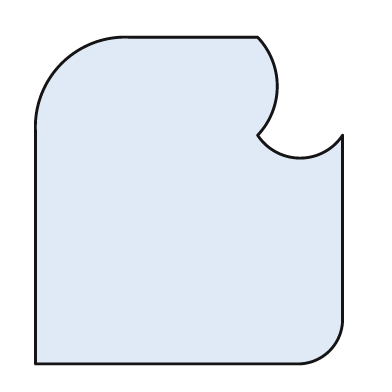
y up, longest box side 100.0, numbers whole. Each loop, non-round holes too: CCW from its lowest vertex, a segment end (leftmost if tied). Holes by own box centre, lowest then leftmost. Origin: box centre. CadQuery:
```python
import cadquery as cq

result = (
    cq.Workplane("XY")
    .moveTo(-47.0, -50.0)
    .lineTo(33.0, -50.0)
    .threePointArc((43.0, -46.0), (47.0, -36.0))
    .lineTo(47.0, 20.0)
    .threePointArc((34.0, 13.0), (21.0, 20.0))
    .threePointArc((27.0, 35.0), (21.0, 50.0))
    .lineTo(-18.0, 50.0)
    .threePointArc((-39.0, 42.0), (-47.0, 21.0))
    .close()
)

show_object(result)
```